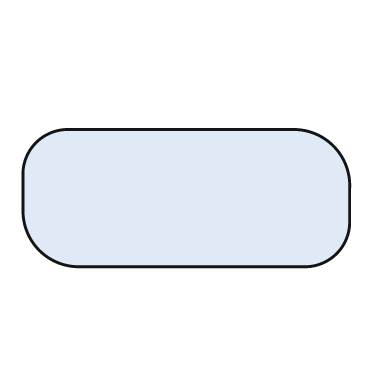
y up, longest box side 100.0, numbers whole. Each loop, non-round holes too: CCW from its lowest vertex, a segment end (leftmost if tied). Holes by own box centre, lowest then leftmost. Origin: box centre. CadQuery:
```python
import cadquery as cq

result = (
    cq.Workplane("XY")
    .moveTo(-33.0, -21.0)
    .lineTo(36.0, -21.0)
    .threePointArc((46.0, -17.0), (50.0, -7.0))
    .lineTo(50.0, 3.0)
    .threePointArc((45.0, 16.0), (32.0, 21.0))
    .lineTo(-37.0, 21.0)
    .threePointArc((-46.0, 17.0), (-50.0, 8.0))
    .lineTo(-50.0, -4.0)
    .threePointArc((-45.0, -16.0), (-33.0, -21.0))
    .close()
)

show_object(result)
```